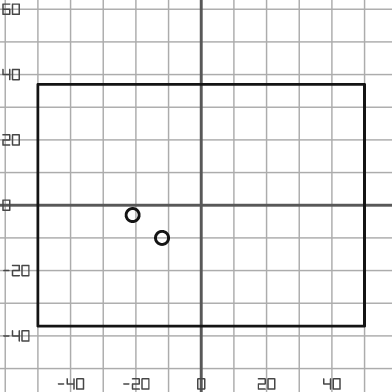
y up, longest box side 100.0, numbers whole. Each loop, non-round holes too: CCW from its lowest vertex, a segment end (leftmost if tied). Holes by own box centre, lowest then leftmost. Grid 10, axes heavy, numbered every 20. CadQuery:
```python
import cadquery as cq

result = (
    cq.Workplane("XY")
    .moveTo(-50.0, -37.0)
    .lineTo(50.0, -37.0)
    .lineTo(50.0, 37.0)
    .lineTo(-50.0, 37.0)
    .close()
    .moveTo(-12.0, -10.0)
    .circle(2.0)
    .moveTo(-21.0, -3.0)
    .circle(2.0)
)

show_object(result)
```